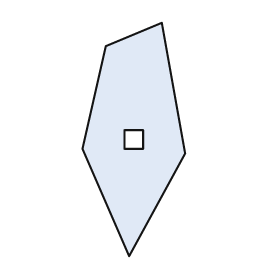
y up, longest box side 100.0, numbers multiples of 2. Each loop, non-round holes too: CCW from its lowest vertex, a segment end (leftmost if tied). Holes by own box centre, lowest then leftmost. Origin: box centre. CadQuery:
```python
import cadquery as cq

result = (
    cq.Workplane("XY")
    .moveTo(-2.0, -50.0)
    .lineTo(22.0, -6.0)
    .lineTo(12.0, 50.0)
    .lineTo(-12.0, 40.0)
    .lineTo(-22.0, -4.0)
    .close()
    .moveTo(-4.0, -4.0)
    .lineTo(4.0, -4.0)
    .lineTo(4.0, 4.0)
    .lineTo(-4.0, 4.0)
    .close()
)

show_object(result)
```